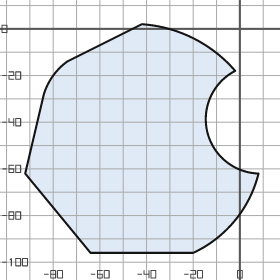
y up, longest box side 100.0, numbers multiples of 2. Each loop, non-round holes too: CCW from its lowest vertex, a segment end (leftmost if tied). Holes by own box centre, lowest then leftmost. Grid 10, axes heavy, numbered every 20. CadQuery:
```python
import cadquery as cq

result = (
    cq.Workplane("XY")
    .moveTo(-64.0, -96.0)
    .lineTo(-20.0, -96.0)
    .threePointArc((-2.0, -82.0), (8.0, -62.0))
    .threePointArc((-14.0, -44.0), (-2.0, -18.0))
    .threePointArc((-20.0, -4.0), (-42.0, 2.0))
    .lineTo(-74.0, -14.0)
    .threePointArc((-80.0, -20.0), (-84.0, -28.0))
    .lineTo(-92.0, -62.0)
    .close()
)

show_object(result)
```